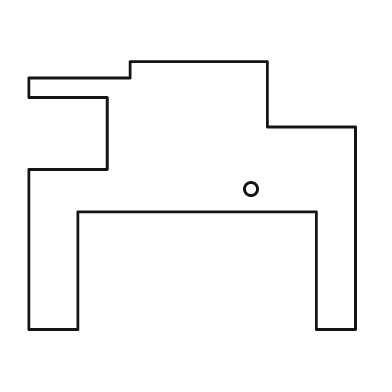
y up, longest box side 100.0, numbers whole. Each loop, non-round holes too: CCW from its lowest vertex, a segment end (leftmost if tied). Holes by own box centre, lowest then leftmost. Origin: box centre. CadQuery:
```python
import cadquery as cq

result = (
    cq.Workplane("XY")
    .moveTo(-50.0, -41.0)
    .lineTo(-35.0, -41.0)
    .lineTo(-35.0, -5.0)
    .lineTo(38.0, -5.0)
    .lineTo(38.0, -41.0)
    .lineTo(50.0, -41.0)
    .lineTo(50.0, 21.0)
    .lineTo(23.0, 21.0)
    .lineTo(23.0, 41.0)
    .lineTo(-19.0, 41.0)
    .lineTo(-19.0, 36.0)
    .lineTo(-50.0, 36.0)
    .lineTo(-50.0, 30.0)
    .lineTo(-26.0, 30.0)
    .lineTo(-26.0, 8.0)
    .lineTo(-50.0, 8.0)
    .close()
    .moveTo(18.0, 2.0)
    .circle(2.0)
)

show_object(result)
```